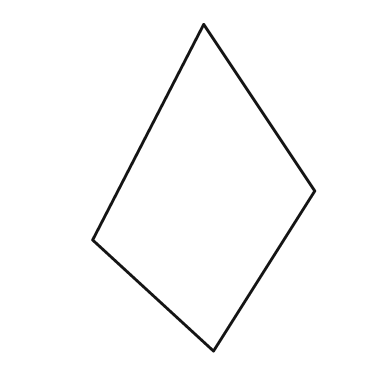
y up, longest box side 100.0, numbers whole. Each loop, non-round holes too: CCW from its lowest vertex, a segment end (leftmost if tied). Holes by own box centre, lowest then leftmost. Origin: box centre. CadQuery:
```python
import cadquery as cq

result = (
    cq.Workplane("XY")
    .moveTo(3.0, -50.0)
    .lineTo(34.0, -1.0)
    .lineTo(0.0, 50.0)
    .lineTo(-34.0, -16.0)
    .close()
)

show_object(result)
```